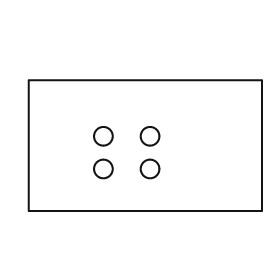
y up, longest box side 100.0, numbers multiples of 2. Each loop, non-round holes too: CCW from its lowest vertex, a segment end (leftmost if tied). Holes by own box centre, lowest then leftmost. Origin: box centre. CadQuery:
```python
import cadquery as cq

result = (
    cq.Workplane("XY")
    .moveTo(-50.0, -28.0)
    .lineTo(50.0, -28.0)
    .lineTo(50.0, 28.0)
    .lineTo(-50.0, 28.0)
    .close()
    .moveTo(-18.0, -10.0)
    .circle(4.0)
    .moveTo(2.0, -10.0)
    .circle(4.0)
    .moveTo(-18.0, 4.0)
    .circle(4.0)
    .moveTo(2.0, 4.0)
    .circle(4.0)
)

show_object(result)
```